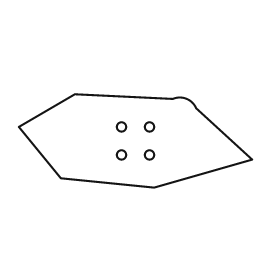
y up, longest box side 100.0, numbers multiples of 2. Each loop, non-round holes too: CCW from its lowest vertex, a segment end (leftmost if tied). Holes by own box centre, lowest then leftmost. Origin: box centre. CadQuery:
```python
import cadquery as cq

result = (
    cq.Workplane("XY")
    .moveTo(8.0, -20.0)
    .lineTo(50.0, -8.0)
    .lineTo(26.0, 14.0)
    .threePointArc((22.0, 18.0), (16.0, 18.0))
    .lineTo(-26.0, 20.0)
    .lineTo(-50.0, 6.0)
    .lineTo(-32.0, -16.0)
    .close()
    .moveTo(-6.0, -6.0)
    .circle(2.0)
    .moveTo(6.0, -6.0)
    .circle(2.0)
    .moveTo(-6.0, 6.0)
    .circle(2.0)
    .moveTo(6.0, 6.0)
    .circle(2.0)
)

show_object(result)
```